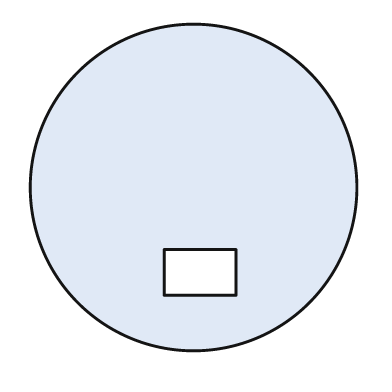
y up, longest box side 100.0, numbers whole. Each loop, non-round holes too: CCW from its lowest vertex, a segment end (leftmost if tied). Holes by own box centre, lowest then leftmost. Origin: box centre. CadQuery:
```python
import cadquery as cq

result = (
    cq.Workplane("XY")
    .moveTo(0.0, 0.0)
    .circle(50.0)
    .moveTo(-9.0, -33.0)
    .lineTo(13.0, -33.0)
    .lineTo(13.0, -19.0)
    .lineTo(-9.0, -19.0)
    .close()
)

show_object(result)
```